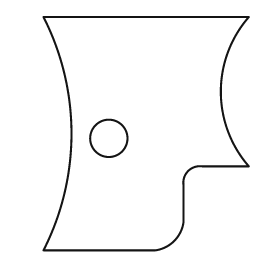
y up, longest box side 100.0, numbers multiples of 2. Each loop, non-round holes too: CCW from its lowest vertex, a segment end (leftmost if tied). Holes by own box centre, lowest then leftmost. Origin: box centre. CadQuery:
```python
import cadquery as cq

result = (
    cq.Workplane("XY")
    .moveTo(-44.0, -50.0)
    .lineTo(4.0, -50.0)
    .threePointArc((12.0, -46.0), (16.0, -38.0))
    .lineTo(16.0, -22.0)
    .threePointArc((18.0, -16.0), (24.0, -14.0))
    .lineTo(44.0, -14.0)
    .threePointArc((32.0, 18.0), (44.0, 50.0))
    .lineTo(-44.0, 50.0)
    .threePointArc((-32.0, 0.0), (-44.0, -50.0))
    .close()
    .moveTo(-16.0, -2.0)
    .circle(8.0)
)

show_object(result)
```